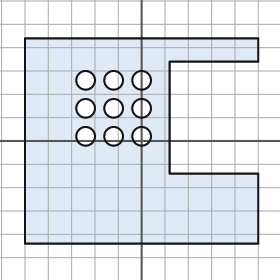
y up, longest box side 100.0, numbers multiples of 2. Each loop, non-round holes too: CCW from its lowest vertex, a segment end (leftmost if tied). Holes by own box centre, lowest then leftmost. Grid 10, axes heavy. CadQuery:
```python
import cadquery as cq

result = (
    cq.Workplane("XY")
    .moveTo(-50.0, -44.0)
    .lineTo(50.0, -44.0)
    .lineTo(50.0, -14.0)
    .lineTo(12.0, -14.0)
    .lineTo(12.0, 34.0)
    .lineTo(50.0, 34.0)
    .lineTo(50.0, 44.0)
    .lineTo(-50.0, 44.0)
    .close()
    .moveTo(-24.0, 2.0)
    .circle(4.0)
    .moveTo(-12.0, 2.0)
    .circle(4.0)
    .moveTo(0.0, 2.0)
    .circle(4.0)
    .moveTo(-24.0, 14.0)
    .circle(4.0)
    .moveTo(-12.0, 14.0)
    .circle(4.0)
    .moveTo(0.0, 14.0)
    .circle(4.0)
    .moveTo(-24.0, 26.0)
    .circle(4.0)
    .moveTo(-12.0, 26.0)
    .circle(4.0)
    .moveTo(0.0, 26.0)
    .circle(4.0)
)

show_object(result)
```